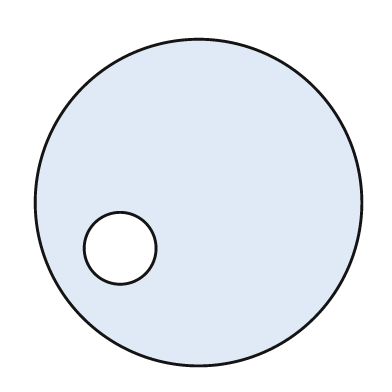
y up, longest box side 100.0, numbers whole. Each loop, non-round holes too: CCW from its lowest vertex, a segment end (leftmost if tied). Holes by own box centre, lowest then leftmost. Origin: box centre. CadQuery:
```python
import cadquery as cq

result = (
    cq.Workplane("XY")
    .moveTo(0.0, 0.0)
    .circle(50.0)
    .moveTo(-24.0, -14.0)
    .circle(11.0)
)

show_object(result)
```